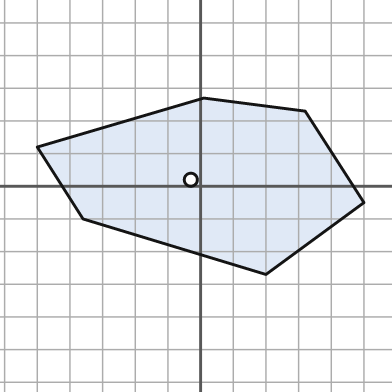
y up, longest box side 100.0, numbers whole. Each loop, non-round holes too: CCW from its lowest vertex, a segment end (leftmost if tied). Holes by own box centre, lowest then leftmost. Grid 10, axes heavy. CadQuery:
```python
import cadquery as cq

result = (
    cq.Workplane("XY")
    .moveTo(20.0, -27.0)
    .lineTo(50.0, -5.0)
    .lineTo(32.0, 23.0)
    .lineTo(1.0, 27.0)
    .lineTo(-50.0, 12.0)
    .lineTo(-36.0, -10.0)
    .close()
    .moveTo(-3.0, 2.0)
    .circle(2.0)
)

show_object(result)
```